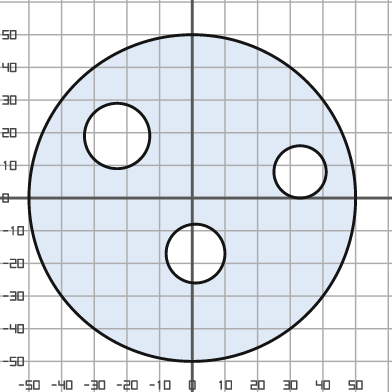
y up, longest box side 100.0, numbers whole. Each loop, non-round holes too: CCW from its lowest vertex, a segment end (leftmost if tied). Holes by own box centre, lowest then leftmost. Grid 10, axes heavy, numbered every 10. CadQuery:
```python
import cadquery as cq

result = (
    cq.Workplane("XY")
    .moveTo(0.0, 0.0)
    .circle(50.0)
    .moveTo(1.0, -17.0)
    .circle(9.0)
    .moveTo(33.0, 8.0)
    .circle(8.0)
    .moveTo(-23.0, 19.0)
    .circle(10.0)
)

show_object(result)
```